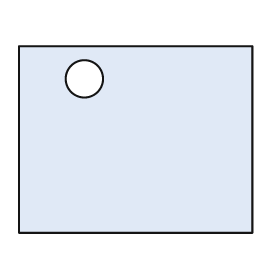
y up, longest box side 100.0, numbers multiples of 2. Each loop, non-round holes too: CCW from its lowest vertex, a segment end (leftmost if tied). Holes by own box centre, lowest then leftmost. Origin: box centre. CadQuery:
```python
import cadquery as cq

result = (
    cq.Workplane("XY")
    .moveTo(-50.0, -40.0)
    .lineTo(50.0, -40.0)
    .lineTo(50.0, 40.0)
    .lineTo(-50.0, 40.0)
    .close()
    .moveTo(-22.0, 26.0)
    .circle(8.0)
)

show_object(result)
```